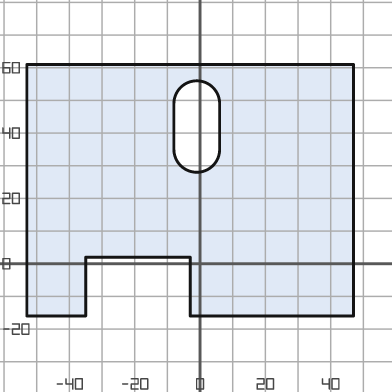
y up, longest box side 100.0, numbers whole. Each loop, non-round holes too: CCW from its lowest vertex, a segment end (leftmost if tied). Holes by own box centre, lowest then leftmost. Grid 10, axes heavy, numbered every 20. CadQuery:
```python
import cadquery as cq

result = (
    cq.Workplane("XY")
    .moveTo(-53.0, -16.0)
    .lineTo(-35.0, -16.0)
    .lineTo(-35.0, 2.0)
    .lineTo(-3.0, 2.0)
    .lineTo(-3.0, -16.0)
    .lineTo(47.0, -16.0)
    .lineTo(47.0, 61.0)
    .lineTo(-53.0, 61.0)
    .close()
    .moveTo(-8.0, 35.0)
    .threePointArc((-1.0, 28.0), (6.0, 35.0))
    .lineTo(6.0, 49.0)
    .threePointArc((-1.0, 56.0), (-8.0, 49.0))
    .close()
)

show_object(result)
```